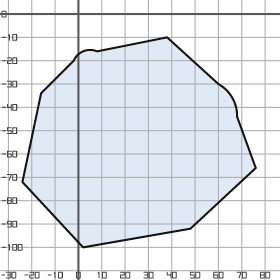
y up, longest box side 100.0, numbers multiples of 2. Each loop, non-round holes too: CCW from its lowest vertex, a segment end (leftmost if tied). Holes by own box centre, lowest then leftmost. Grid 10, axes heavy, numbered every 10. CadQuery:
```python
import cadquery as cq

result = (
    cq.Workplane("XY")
    .moveTo(2.0, -100.0)
    .lineTo(48.0, -92.0)
    .lineTo(76.0, -66.0)
    .lineTo(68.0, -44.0)
    .threePointArc((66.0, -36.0), (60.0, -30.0))
    .lineTo(38.0, -10.0)
    .lineTo(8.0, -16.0)
    .threePointArc((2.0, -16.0), (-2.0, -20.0))
    .lineTo(-16.0, -34.0)
    .lineTo(-24.0, -72.0)
    .close()
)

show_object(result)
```